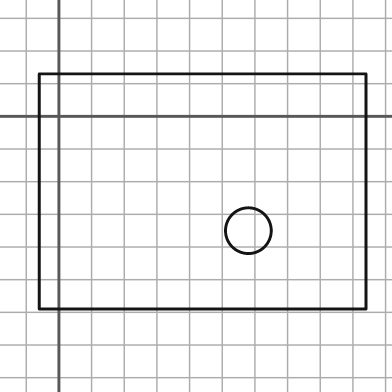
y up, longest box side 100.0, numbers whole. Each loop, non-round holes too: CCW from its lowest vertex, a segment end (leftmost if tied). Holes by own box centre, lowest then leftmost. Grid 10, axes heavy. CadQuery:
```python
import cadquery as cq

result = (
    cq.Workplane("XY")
    .moveTo(-6.0, -59.0)
    .lineTo(94.0, -59.0)
    .lineTo(94.0, 13.0)
    .lineTo(-6.0, 13.0)
    .close()
    .moveTo(58.0, -35.0)
    .circle(7.0)
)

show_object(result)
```